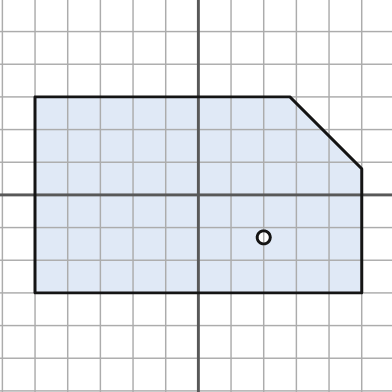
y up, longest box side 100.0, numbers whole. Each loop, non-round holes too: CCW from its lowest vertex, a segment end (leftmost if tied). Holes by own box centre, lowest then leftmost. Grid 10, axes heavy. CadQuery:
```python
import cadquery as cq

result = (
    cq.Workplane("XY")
    .moveTo(-50.0, -30.0)
    .lineTo(50.0, -30.0)
    .lineTo(50.0, 8.0)
    .lineTo(28.0, 30.0)
    .lineTo(-50.0, 30.0)
    .close()
    .moveTo(20.0, -13.0)
    .circle(2.0)
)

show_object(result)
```